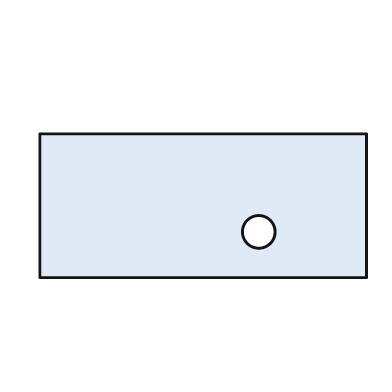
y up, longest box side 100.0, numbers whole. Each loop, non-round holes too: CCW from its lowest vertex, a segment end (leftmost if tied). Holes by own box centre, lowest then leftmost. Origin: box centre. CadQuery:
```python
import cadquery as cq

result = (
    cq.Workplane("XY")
    .moveTo(-50.0, -22.0)
    .lineTo(50.0, -22.0)
    .lineTo(50.0, 22.0)
    .lineTo(-50.0, 22.0)
    .close()
    .moveTo(17.0, -8.0)
    .circle(5.0)
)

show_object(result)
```